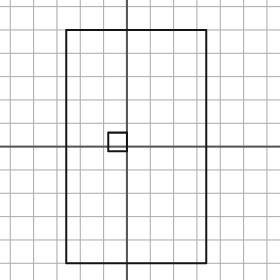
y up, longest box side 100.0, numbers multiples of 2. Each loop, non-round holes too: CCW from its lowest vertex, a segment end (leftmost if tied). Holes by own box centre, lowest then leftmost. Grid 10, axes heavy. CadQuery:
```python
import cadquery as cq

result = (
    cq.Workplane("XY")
    .moveTo(-26.0, -50.0)
    .lineTo(34.0, -50.0)
    .lineTo(34.0, 50.0)
    .lineTo(-26.0, 50.0)
    .close()
    .moveTo(-8.0, -2.0)
    .lineTo(0.0, -2.0)
    .lineTo(0.0, 6.0)
    .lineTo(-8.0, 6.0)
    .close()
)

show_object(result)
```